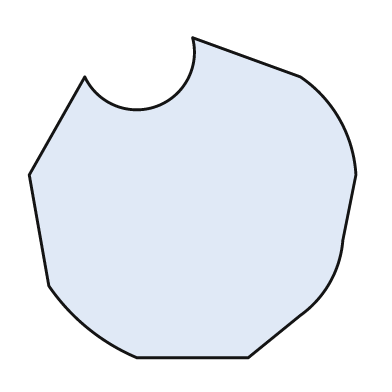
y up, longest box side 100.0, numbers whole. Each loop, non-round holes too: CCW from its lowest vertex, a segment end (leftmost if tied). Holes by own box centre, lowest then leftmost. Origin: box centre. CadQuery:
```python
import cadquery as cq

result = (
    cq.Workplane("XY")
    .moveTo(-17.0, -49.0)
    .lineTo(17.0, -49.0)
    .lineTo(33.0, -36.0)
    .threePointArc((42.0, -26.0), (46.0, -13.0))
    .lineTo(50.0, 7.0)
    .threePointArc((45.0, 24.0), (33.0, 37.0))
    .lineTo(0.0, 49.0)
    .threePointArc((-11.0, 28.0), (-33.0, 37.0))
    .lineTo(-50.0, 7.0)
    .lineTo(-44.0, -27.0)
    .threePointArc((-32.0, -40.0), (-17.0, -49.0))
    .close()
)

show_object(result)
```